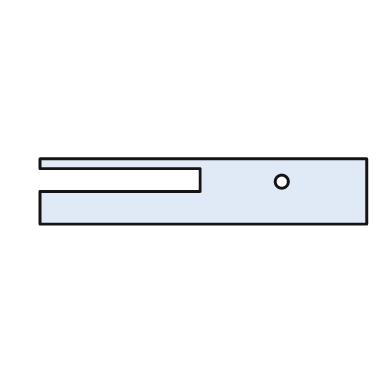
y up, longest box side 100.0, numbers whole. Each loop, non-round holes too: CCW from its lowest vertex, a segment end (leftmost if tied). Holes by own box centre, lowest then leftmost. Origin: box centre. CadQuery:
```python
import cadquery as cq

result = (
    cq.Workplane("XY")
    .moveTo(-50.0, -10.0)
    .lineTo(50.0, -10.0)
    .lineTo(50.0, 10.0)
    .lineTo(-50.0, 10.0)
    .lineTo(-50.0, 7.0)
    .lineTo(-1.0, 7.0)
    .lineTo(-1.0, 0.0)
    .lineTo(-50.0, 0.0)
    .close()
    .moveTo(24.0, 3.0)
    .circle(2.0)
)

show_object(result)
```